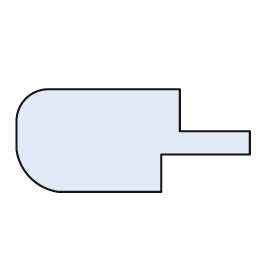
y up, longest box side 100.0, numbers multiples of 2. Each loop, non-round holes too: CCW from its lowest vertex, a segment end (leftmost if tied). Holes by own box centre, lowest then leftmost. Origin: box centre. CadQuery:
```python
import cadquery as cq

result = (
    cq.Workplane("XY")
    .moveTo(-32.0, -22.0)
    .lineTo(12.0, -22.0)
    .lineTo(12.0, -6.0)
    .lineTo(50.0, -6.0)
    .lineTo(50.0, 4.0)
    .lineTo(20.0, 4.0)
    .lineTo(20.0, 22.0)
    .lineTo(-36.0, 22.0)
    .threePointArc((-46.0, 18.0), (-50.0, 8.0))
    .lineTo(-50.0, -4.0)
    .threePointArc((-44.0, -16.0), (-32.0, -22.0))
    .close()
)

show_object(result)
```